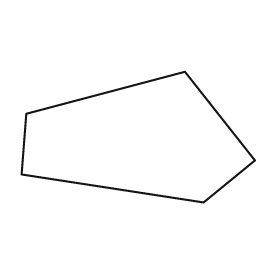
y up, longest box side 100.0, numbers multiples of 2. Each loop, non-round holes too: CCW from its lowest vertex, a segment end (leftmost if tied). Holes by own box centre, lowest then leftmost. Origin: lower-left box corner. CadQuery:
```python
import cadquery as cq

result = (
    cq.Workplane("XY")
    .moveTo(78.0, 0.0)
    .lineTo(100.0, 18.0)
    .lineTo(70.0, 56.0)
    .lineTo(2.0, 38.0)
    .lineTo(0.0, 12.0)
    .close()
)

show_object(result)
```